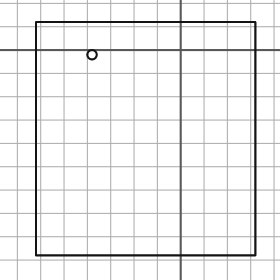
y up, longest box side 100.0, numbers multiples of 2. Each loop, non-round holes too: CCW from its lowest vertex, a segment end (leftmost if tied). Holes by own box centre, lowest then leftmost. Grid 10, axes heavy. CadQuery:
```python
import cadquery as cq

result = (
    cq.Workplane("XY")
    .moveTo(-62.0, -88.0)
    .lineTo(32.0, -88.0)
    .lineTo(32.0, 12.0)
    .lineTo(-62.0, 12.0)
    .close()
    .moveTo(-38.0, -2.0)
    .circle(2.0)
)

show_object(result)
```